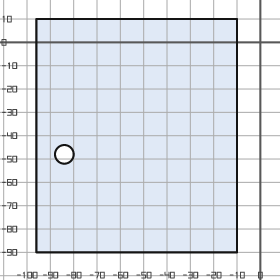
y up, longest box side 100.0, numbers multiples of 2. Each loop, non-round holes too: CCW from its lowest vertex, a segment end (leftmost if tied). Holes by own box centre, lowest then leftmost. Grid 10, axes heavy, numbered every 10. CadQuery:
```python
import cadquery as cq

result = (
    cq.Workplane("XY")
    .moveTo(-96.0, -90.0)
    .lineTo(-10.0, -90.0)
    .lineTo(-10.0, 10.0)
    .lineTo(-96.0, 10.0)
    .close()
    .moveTo(-84.0, -48.0)
    .circle(4.0)
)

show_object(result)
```